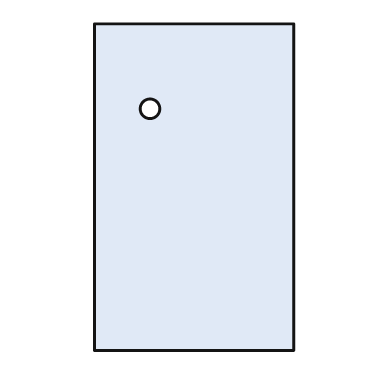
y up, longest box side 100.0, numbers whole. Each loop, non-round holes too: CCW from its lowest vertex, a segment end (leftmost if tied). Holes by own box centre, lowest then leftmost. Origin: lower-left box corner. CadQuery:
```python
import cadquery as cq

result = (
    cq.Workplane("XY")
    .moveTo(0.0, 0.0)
    .lineTo(61.0, 0.0)
    .lineTo(61.0, 100.0)
    .lineTo(0.0, 100.0)
    .close()
    .moveTo(17.0, 74.0)
    .circle(3.0)
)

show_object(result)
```